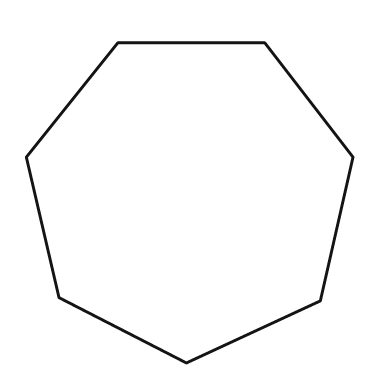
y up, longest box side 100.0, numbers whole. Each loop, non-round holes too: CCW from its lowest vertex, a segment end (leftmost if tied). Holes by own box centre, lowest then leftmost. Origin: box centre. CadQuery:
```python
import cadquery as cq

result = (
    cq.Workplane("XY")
    .moveTo(-1.0, -49.0)
    .lineTo(40.0, -30.0)
    .lineTo(50.0, 14.0)
    .lineTo(23.0, 49.0)
    .lineTo(-22.0, 49.0)
    .lineTo(-50.0, 14.0)
    .lineTo(-40.0, -29.0)
    .close()
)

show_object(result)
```